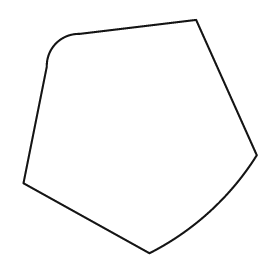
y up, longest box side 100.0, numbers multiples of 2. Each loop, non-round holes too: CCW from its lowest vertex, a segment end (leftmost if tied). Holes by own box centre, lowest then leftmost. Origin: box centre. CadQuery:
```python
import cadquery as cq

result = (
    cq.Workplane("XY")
    .moveTo(4.0, -50.0)
    .threePointArc((30.0, -32.0), (50.0, -8.0))
    .lineTo(24.0, 50.0)
    .lineTo(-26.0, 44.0)
    .threePointArc((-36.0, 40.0), (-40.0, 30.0))
    .lineTo(-50.0, -20.0)
    .close()
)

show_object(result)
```